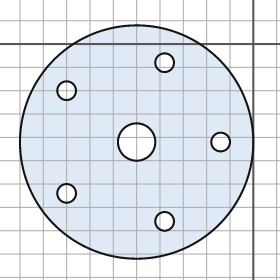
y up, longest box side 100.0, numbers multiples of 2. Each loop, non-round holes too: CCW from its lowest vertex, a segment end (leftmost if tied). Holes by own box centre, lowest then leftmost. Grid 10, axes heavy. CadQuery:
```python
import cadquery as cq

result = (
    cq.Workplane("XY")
    .moveTo(-50.0, -42.0)
    .circle(50.0)
    .moveTo(-38.0, -76.0)
    .circle(4.0)
    .moveTo(-80.0, -64.0)
    .circle(4.0)
    .moveTo(-50.0, -42.0)
    .circle(8.0)
    .moveTo(-14.0, -42.0)
    .circle(4.0)
    .moveTo(-80.0, -20.0)
    .circle(4.0)
    .moveTo(-38.0, -8.0)
    .circle(4.0)
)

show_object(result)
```